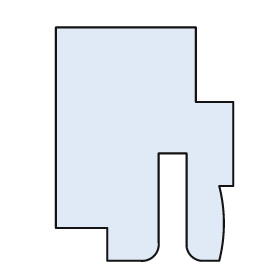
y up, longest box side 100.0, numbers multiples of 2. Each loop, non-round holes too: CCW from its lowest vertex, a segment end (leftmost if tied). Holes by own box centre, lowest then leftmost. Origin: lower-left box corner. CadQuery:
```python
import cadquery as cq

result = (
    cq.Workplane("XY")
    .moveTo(22.0, 0.0)
    .lineTo(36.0, 0.0)
    .threePointArc((42.0, 2.0), (44.0, 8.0))
    .lineTo(44.0, 46.0)
    .lineTo(56.0, 46.0)
    .lineTo(56.0, 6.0)
    .threePointArc((58.0, 2.0), (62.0, 0.0))
    .lineTo(70.0, 0.0)
    .threePointArc((72.0, 16.0), (70.0, 32.0))
    .lineTo(76.0, 32.0)
    .lineTo(76.0, 68.0)
    .lineTo(60.0, 68.0)
    .lineTo(60.0, 100.0)
    .lineTo(0.0, 100.0)
    .lineTo(0.0, 14.0)
    .lineTo(22.0, 14.0)
    .close()
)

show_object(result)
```